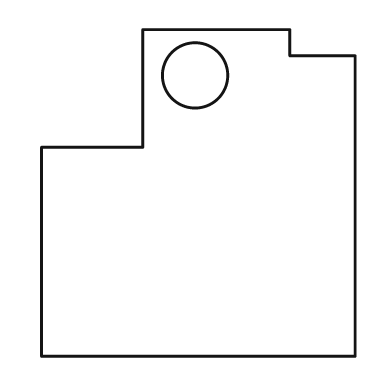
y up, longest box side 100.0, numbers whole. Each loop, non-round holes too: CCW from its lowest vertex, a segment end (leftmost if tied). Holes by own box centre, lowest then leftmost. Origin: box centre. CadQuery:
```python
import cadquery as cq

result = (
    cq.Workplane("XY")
    .moveTo(-48.0, -50.0)
    .lineTo(48.0, -50.0)
    .lineTo(48.0, 42.0)
    .lineTo(28.0, 42.0)
    .lineTo(28.0, 50.0)
    .lineTo(-17.0, 50.0)
    .lineTo(-17.0, 14.0)
    .lineTo(-48.0, 14.0)
    .close()
    .moveTo(-1.0, 36.0)
    .circle(10.0)
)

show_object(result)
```